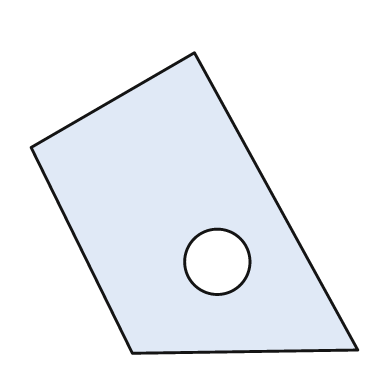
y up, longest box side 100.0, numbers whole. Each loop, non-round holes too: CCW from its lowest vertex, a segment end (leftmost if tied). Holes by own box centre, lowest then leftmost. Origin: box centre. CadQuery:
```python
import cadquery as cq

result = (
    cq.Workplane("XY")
    .moveTo(-19.0, -46.0)
    .lineTo(50.0, -45.0)
    .lineTo(0.0, 46.0)
    .lineTo(-50.0, 17.0)
    .close()
    .moveTo(7.0, -18.0)
    .circle(10.0)
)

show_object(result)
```